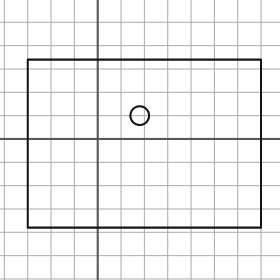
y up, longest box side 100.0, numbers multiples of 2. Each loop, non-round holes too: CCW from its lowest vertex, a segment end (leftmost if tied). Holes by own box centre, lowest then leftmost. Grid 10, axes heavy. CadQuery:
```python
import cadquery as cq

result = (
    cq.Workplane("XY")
    .moveTo(-30.0, -38.0)
    .lineTo(70.0, -38.0)
    .lineTo(70.0, 34.0)
    .lineTo(-30.0, 34.0)
    .close()
    .moveTo(18.0, 10.0)
    .circle(4.0)
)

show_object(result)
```